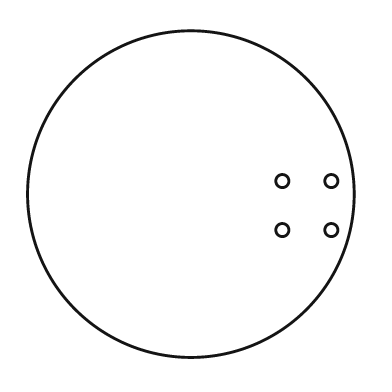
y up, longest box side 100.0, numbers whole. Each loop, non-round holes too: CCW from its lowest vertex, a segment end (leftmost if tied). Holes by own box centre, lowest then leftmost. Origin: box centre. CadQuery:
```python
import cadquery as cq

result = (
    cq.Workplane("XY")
    .moveTo(0.0, 0.0)
    .circle(50.0)
    .moveTo(28.0, -11.0)
    .circle(2.0)
    .moveTo(43.0, -11.0)
    .circle(2.0)
    .moveTo(28.0, 4.0)
    .circle(2.0)
    .moveTo(43.0, 4.0)
    .circle(2.0)
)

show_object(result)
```